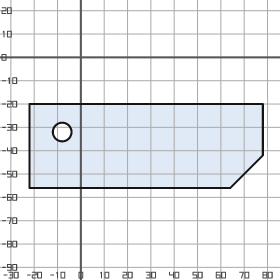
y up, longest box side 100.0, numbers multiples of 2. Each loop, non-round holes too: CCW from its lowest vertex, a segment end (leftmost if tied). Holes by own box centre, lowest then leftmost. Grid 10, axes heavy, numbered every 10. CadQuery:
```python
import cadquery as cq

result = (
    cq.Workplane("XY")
    .moveTo(-22.0, -56.0)
    .lineTo(64.0, -56.0)
    .lineTo(78.0, -42.0)
    .lineTo(78.0, -20.0)
    .lineTo(-22.0, -20.0)
    .close()
    .moveTo(-8.0, -32.0)
    .circle(4.0)
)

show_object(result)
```